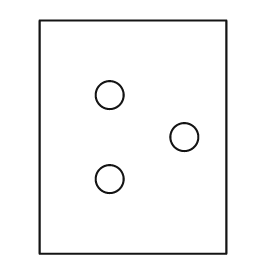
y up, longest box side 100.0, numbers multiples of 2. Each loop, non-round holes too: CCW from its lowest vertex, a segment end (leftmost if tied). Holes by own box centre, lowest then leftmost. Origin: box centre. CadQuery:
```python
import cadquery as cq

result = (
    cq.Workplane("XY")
    .moveTo(-40.0, -50.0)
    .lineTo(40.0, -50.0)
    .lineTo(40.0, 50.0)
    .lineTo(-40.0, 50.0)
    .close()
    .moveTo(-10.0, -18.0)
    .circle(6.0)
    .moveTo(22.0, 0.0)
    .circle(6.0)
    .moveTo(-10.0, 18.0)
    .circle(6.0)
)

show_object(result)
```